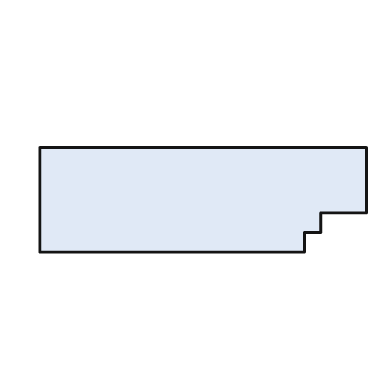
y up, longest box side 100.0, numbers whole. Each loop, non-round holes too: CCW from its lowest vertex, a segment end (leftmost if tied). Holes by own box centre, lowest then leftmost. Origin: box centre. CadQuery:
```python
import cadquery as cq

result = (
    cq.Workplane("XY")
    .moveTo(-50.0, -16.0)
    .lineTo(31.0, -16.0)
    .lineTo(31.0, -10.0)
    .lineTo(36.0, -10.0)
    .lineTo(36.0, -4.0)
    .lineTo(50.0, -4.0)
    .lineTo(50.0, 16.0)
    .lineTo(-50.0, 16.0)
    .close()
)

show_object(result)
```